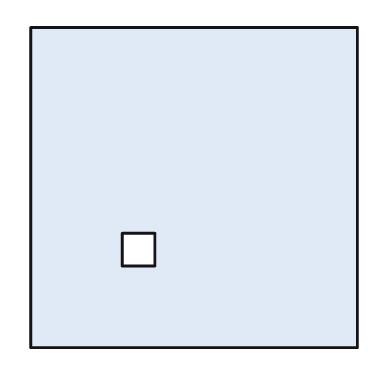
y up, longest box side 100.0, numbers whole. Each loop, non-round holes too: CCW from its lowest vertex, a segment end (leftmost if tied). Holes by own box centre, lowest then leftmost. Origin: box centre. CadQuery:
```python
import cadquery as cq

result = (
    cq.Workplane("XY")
    .moveTo(-50.0, -49.0)
    .lineTo(50.0, -49.0)
    .lineTo(50.0, 49.0)
    .lineTo(-50.0, 49.0)
    .close()
    .moveTo(-22.0, -24.0)
    .lineTo(-12.0, -24.0)
    .lineTo(-12.0, -14.0)
    .lineTo(-22.0, -14.0)
    .close()
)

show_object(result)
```